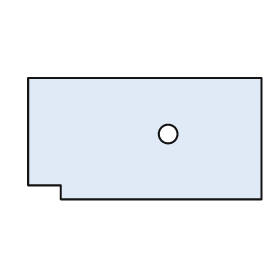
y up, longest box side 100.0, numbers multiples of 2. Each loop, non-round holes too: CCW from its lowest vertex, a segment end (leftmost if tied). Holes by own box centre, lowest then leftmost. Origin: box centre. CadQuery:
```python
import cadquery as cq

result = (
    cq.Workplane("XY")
    .moveTo(-36.0, -26.0)
    .lineTo(50.0, -26.0)
    .lineTo(50.0, 26.0)
    .lineTo(-50.0, 26.0)
    .lineTo(-50.0, -20.0)
    .lineTo(-36.0, -20.0)
    .close()
    .moveTo(10.0, 2.0)
    .circle(4.0)
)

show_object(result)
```